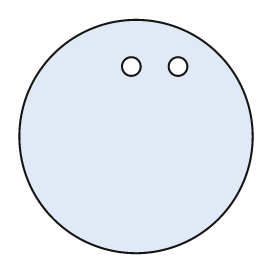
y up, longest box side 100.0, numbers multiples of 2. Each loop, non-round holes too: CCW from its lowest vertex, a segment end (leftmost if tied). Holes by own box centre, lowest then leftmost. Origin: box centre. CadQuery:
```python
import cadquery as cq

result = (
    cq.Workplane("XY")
    .moveTo(0.0, 0.0)
    .circle(50.0)
    .moveTo(-2.0, 30.0)
    .circle(4.0)
    .moveTo(18.0, 30.0)
    .circle(4.0)
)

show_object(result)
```